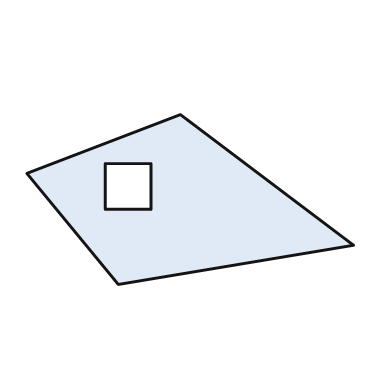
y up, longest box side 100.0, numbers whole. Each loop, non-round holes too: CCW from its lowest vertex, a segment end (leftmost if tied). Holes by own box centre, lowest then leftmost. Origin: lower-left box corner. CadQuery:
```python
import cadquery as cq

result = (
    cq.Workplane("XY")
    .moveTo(28.0, 0.0)
    .lineTo(100.0, 12.0)
    .lineTo(47.0, 52.0)
    .lineTo(0.0, 34.0)
    .close()
    .moveTo(24.0, 23.0)
    .lineTo(38.0, 23.0)
    .lineTo(38.0, 37.0)
    .lineTo(24.0, 37.0)
    .close()
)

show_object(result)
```